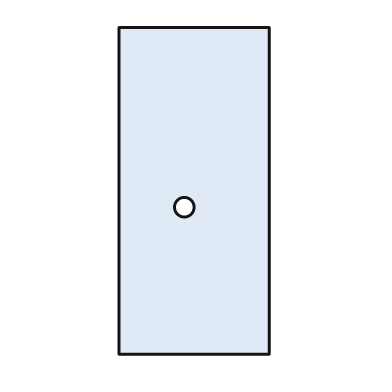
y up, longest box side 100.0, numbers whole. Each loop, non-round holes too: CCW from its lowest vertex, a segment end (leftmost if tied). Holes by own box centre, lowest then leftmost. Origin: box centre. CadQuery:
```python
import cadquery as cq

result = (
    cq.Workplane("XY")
    .moveTo(-23.0, -50.0)
    .lineTo(23.0, -50.0)
    .lineTo(23.0, 50.0)
    .lineTo(-23.0, 50.0)
    .close()
    .moveTo(-3.0, -5.0)
    .circle(3.0)
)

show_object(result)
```